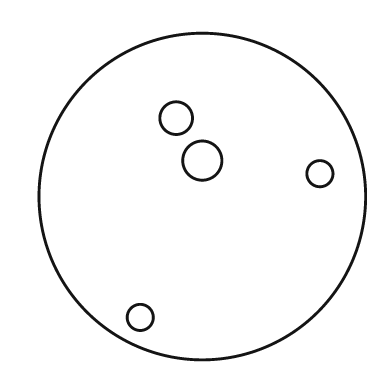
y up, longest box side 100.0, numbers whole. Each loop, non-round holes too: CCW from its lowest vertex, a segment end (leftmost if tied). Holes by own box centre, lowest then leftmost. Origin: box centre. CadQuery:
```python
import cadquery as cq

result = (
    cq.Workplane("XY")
    .moveTo(0.0, 0.0)
    .circle(50.0)
    .moveTo(-19.0, -37.0)
    .circle(4.0)
    .moveTo(36.0, 7.0)
    .circle(4.0)
    .moveTo(0.0, 11.0)
    .circle(6.0)
    .moveTo(-8.0, 24.0)
    .circle(5.0)
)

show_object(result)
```